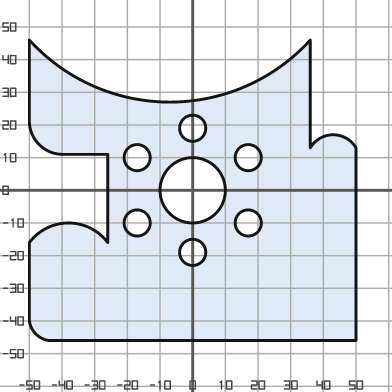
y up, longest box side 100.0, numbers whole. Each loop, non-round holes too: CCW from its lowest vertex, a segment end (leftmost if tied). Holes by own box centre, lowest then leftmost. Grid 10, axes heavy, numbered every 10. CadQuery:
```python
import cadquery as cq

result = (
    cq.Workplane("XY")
    .moveTo(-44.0, -46.0)
    .lineTo(50.0, -46.0)
    .lineTo(50.0, 13.0)
    .threePointArc((43.0, 17.0), (36.0, 13.0))
    .lineTo(36.0, 46.0)
    .threePointArc((-7.0, 27.0), (-50.0, 46.0))
    .lineTo(-50.0, 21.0)
    .threePointArc((-47.0, 14.0), (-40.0, 11.0))
    .lineTo(-26.0, 11.0)
    .lineTo(-26.0, -16.0)
    .threePointArc((-38.0, -10.0), (-50.0, -16.0))
    .lineTo(-50.0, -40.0)
    .threePointArc((-48.0, -44.0), (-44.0, -46.0))
    .close()
    .moveTo(0.0, -19.0)
    .circle(4.0)
    .moveTo(-17.0, -10.0)
    .circle(4.0)
    .moveTo(17.0, -10.0)
    .circle(4.0)
    .moveTo(0.0, 0.0)
    .circle(10.0)
    .moveTo(-17.0, 10.0)
    .circle(4.0)
    .moveTo(17.0, 10.0)
    .circle(4.0)
    .moveTo(0.0, 19.0)
    .circle(4.0)
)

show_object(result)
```